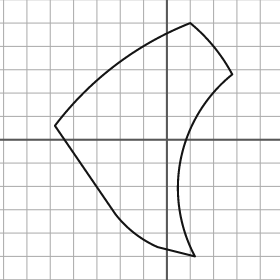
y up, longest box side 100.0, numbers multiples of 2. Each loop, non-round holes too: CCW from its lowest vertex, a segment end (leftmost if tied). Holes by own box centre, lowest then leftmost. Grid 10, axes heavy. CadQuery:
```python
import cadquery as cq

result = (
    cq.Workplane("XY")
    .moveTo(12.0, -50.0)
    .threePointArc((6.0, -8.0), (28.0, 28.0))
    .threePointArc((20.0, 40.0), (10.0, 50.0))
    .threePointArc((-22.0, 32.0), (-48.0, 6.0))
    .lineTo(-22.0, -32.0)
    .threePointArc((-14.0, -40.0), (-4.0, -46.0))
    .close()
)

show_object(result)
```